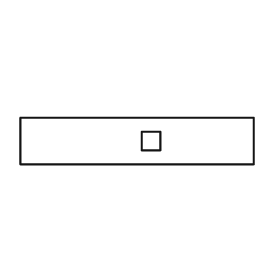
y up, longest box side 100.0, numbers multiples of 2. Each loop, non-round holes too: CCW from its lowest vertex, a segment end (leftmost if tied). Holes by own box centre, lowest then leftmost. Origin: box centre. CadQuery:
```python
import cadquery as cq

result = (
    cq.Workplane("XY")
    .moveTo(-50.0, -10.0)
    .lineTo(50.0, -10.0)
    .lineTo(50.0, 10.0)
    .lineTo(-50.0, 10.0)
    .close()
    .moveTo(2.0, -4.0)
    .lineTo(10.0, -4.0)
    .lineTo(10.0, 4.0)
    .lineTo(2.0, 4.0)
    .close()
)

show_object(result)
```